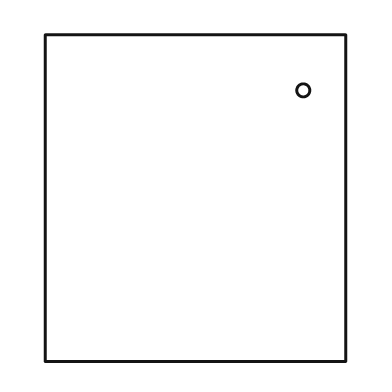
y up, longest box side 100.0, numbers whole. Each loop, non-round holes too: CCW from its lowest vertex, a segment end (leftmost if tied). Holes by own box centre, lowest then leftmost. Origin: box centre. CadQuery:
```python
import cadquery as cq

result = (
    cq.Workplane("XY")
    .moveTo(-46.0, -50.0)
    .lineTo(46.0, -50.0)
    .lineTo(46.0, 50.0)
    .lineTo(-46.0, 50.0)
    .close()
    .moveTo(33.0, 33.0)
    .circle(2.0)
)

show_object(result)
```